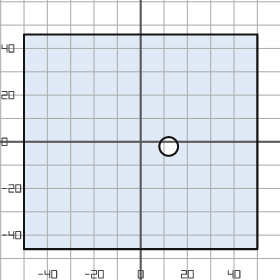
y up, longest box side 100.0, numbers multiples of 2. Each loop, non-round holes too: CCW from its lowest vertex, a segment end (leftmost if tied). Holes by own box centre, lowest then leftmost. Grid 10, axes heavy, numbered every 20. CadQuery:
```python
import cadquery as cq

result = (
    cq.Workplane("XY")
    .moveTo(-50.0, -46.0)
    .lineTo(50.0, -46.0)
    .lineTo(50.0, 46.0)
    .lineTo(-50.0, 46.0)
    .close()
    .moveTo(12.0, -2.0)
    .circle(4.0)
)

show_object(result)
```